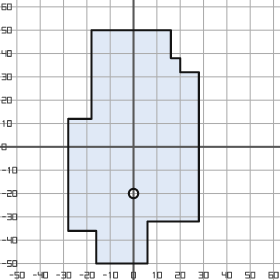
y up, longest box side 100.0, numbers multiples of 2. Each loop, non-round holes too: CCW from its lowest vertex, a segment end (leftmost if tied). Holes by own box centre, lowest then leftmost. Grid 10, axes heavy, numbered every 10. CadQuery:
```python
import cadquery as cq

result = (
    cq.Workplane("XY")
    .moveTo(-16.0, -50.0)
    .lineTo(6.0, -50.0)
    .lineTo(6.0, -32.0)
    .lineTo(28.0, -32.0)
    .lineTo(28.0, 32.0)
    .lineTo(20.0, 32.0)
    .lineTo(20.0, 38.0)
    .lineTo(16.0, 38.0)
    .lineTo(16.0, 50.0)
    .lineTo(-18.0, 50.0)
    .lineTo(-18.0, 12.0)
    .lineTo(-28.0, 12.0)
    .lineTo(-28.0, -36.0)
    .lineTo(-16.0, -36.0)
    .close()
    .moveTo(0.0, -20.0)
    .circle(2.0)
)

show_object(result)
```